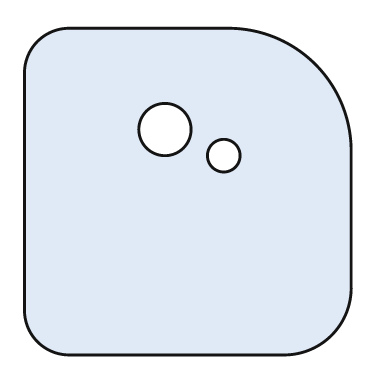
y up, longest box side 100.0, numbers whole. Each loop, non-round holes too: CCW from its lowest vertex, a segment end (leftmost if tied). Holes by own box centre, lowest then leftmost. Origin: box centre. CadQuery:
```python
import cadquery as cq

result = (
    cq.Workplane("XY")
    .moveTo(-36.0, -50.0)
    .lineTo(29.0, -50.0)
    .threePointArc((44.0, -44.0), (50.0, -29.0))
    .lineTo(50.0, 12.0)
    .threePointArc((39.0, 39.0), (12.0, 50.0))
    .lineTo(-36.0, 50.0)
    .threePointArc((-46.0, 46.0), (-50.0, 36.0))
    .lineTo(-50.0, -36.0)
    .threePointArc((-46.0, -46.0), (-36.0, -50.0))
    .close()
    .moveTo(11.0, 11.0)
    .circle(5.0)
    .moveTo(-7.0, 19.0)
    .circle(8.0)
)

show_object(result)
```